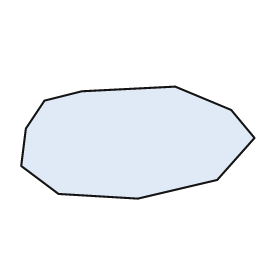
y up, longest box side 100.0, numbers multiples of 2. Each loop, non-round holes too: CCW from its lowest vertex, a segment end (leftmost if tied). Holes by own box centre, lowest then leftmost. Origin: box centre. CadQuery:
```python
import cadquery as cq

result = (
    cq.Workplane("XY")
    .moveTo(0.0, -24.0)
    .lineTo(34.0, -16.0)
    .lineTo(50.0, 2.0)
    .lineTo(40.0, 14.0)
    .lineTo(16.0, 24.0)
    .lineTo(-24.0, 22.0)
    .lineTo(-40.0, 18.0)
    .lineTo(-48.0, 6.0)
    .lineTo(-50.0, -10.0)
    .lineTo(-34.0, -22.0)
    .close()
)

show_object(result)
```